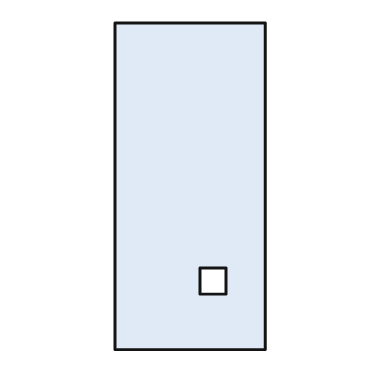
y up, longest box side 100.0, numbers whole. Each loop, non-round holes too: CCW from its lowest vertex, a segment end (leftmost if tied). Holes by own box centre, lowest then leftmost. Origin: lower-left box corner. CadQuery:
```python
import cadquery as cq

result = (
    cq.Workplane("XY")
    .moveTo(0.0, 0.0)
    .lineTo(46.0, 0.0)
    .lineTo(46.0, 100.0)
    .lineTo(0.0, 100.0)
    .close()
    .moveTo(26.0, 17.0)
    .lineTo(34.0, 17.0)
    .lineTo(34.0, 25.0)
    .lineTo(26.0, 25.0)
    .close()
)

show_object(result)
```